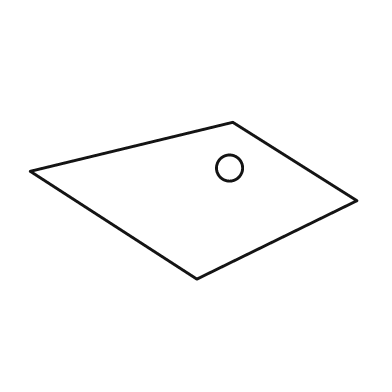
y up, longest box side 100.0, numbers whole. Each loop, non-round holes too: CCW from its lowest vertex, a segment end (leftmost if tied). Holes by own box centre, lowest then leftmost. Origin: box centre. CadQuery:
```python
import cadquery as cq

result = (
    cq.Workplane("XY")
    .moveTo(1.0, -24.0)
    .lineTo(50.0, 0.0)
    .lineTo(12.0, 24.0)
    .lineTo(-50.0, 9.0)
    .close()
    .moveTo(11.0, 10.0)
    .circle(4.0)
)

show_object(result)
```